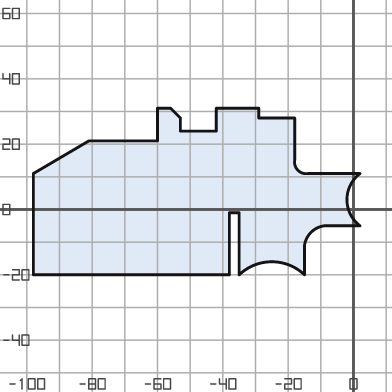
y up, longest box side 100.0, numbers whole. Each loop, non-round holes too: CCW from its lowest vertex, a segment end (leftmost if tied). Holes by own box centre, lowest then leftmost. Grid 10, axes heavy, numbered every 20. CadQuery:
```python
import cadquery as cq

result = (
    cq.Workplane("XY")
    .moveTo(-98.0, -20.0)
    .lineTo(-38.0, -20.0)
    .lineTo(-38.0, -1.0)
    .lineTo(-35.0, -1.0)
    .lineTo(-35.0, -20.0)
    .threePointArc((-25.0, -16.0), (-15.0, -20.0))
    .lineTo(-15.0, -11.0)
    .threePointArc((-13.0, -7.0), (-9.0, -5.0))
    .lineTo(2.0, -5.0)
    .threePointArc((-2.0, 3.0), (2.0, 11.0))
    .lineTo(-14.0, 11.0)
    .threePointArc((-17.0, 12.0), (-18.0, 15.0))
    .lineTo(-18.0, 28.0)
    .lineTo(-29.0, 28.0)
    .lineTo(-29.0, 31.0)
    .lineTo(-42.0, 31.0)
    .lineTo(-42.0, 24.0)
    .lineTo(-53.0, 24.0)
    .lineTo(-53.0, 28.0)
    .lineTo(-56.0, 31.0)
    .lineTo(-60.0, 31.0)
    .lineTo(-60.0, 21.0)
    .lineTo(-81.0, 21.0)
    .lineTo(-98.0, 11.0)
    .close()
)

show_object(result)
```